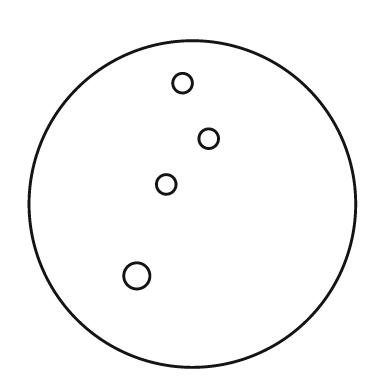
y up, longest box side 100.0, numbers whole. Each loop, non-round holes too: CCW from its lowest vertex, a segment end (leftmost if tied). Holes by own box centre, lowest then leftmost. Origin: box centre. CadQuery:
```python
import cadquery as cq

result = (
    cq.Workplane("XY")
    .moveTo(0.0, 0.0)
    .circle(50.0)
    .moveTo(-17.0, -22.0)
    .circle(4.0)
    .moveTo(-8.0, 6.0)
    .circle(3.0)
    .moveTo(5.0, 20.0)
    .circle(3.0)
    .moveTo(-3.0, 37.0)
    .circle(3.0)
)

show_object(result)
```